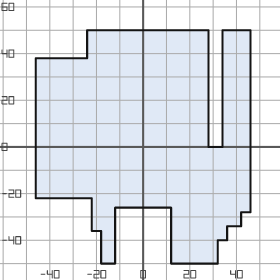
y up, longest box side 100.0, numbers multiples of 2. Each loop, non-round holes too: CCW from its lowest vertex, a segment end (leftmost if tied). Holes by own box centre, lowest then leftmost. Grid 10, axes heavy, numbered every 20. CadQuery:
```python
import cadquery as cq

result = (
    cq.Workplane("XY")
    .moveTo(-18.0, -50.0)
    .lineTo(-12.0, -50.0)
    .lineTo(-12.0, -26.0)
    .lineTo(12.0, -26.0)
    .lineTo(12.0, -50.0)
    .lineTo(32.0, -50.0)
    .lineTo(32.0, -40.0)
    .lineTo(36.0, -40.0)
    .lineTo(36.0, -34.0)
    .lineTo(42.0, -34.0)
    .lineTo(42.0, -28.0)
    .lineTo(46.0, -28.0)
    .lineTo(46.0, 50.0)
    .lineTo(34.0, 50.0)
    .lineTo(34.0, 0.0)
    .lineTo(28.0, 0.0)
    .lineTo(28.0, 50.0)
    .lineTo(-24.0, 50.0)
    .lineTo(-24.0, 38.0)
    .lineTo(-46.0, 38.0)
    .lineTo(-46.0, -22.0)
    .lineTo(-22.0, -22.0)
    .lineTo(-22.0, -36.0)
    .lineTo(-18.0, -36.0)
    .close()
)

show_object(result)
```